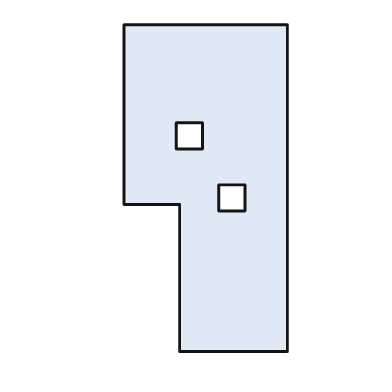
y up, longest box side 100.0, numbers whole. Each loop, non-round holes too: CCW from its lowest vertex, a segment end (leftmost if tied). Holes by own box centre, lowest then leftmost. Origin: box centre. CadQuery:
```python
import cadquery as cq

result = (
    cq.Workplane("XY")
    .moveTo(-8.0, -50.0)
    .lineTo(25.0, -50.0)
    .lineTo(25.0, 50.0)
    .lineTo(-25.0, 50.0)
    .lineTo(-25.0, -5.0)
    .lineTo(-8.0, -5.0)
    .close()
    .moveTo(4.0, -7.0)
    .lineTo(12.0, -7.0)
    .lineTo(12.0, 1.0)
    .lineTo(4.0, 1.0)
    .close()
    .moveTo(-9.0, 12.0)
    .lineTo(-1.0, 12.0)
    .lineTo(-1.0, 20.0)
    .lineTo(-9.0, 20.0)
    .close()
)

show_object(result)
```